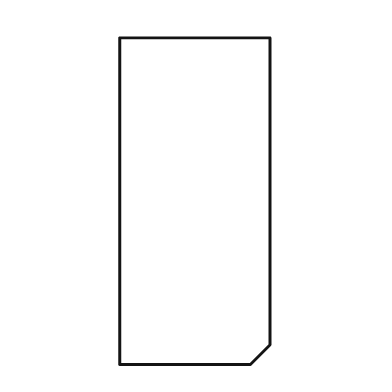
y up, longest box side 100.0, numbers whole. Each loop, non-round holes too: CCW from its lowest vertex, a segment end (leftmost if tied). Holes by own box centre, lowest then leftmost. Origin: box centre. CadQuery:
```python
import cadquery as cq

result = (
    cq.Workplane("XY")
    .moveTo(-23.0, -50.0)
    .lineTo(17.0, -50.0)
    .lineTo(23.0, -44.0)
    .lineTo(23.0, 50.0)
    .lineTo(-23.0, 50.0)
    .close()
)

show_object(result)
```